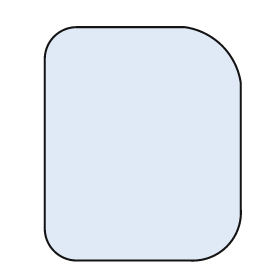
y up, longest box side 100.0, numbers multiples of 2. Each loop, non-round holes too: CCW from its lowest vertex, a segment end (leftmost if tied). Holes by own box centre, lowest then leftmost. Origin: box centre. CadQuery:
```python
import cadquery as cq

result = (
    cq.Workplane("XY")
    .moveTo(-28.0, -50.0)
    .lineTo(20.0, -50.0)
    .threePointArc((36.0, -44.0), (42.0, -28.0))
    .lineTo(42.0, 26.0)
    .threePointArc((34.0, 42.0), (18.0, 50.0))
    .lineTo(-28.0, 50.0)
    .threePointArc((-38.0, 46.0), (-42.0, 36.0))
    .lineTo(-42.0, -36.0)
    .threePointArc((-38.0, -46.0), (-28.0, -50.0))
    .close()
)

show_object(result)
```